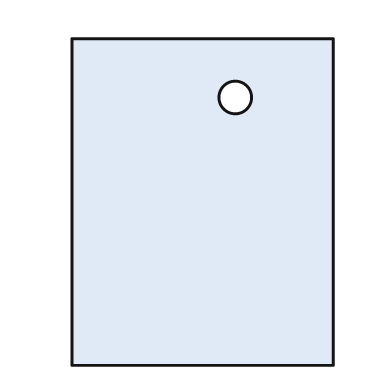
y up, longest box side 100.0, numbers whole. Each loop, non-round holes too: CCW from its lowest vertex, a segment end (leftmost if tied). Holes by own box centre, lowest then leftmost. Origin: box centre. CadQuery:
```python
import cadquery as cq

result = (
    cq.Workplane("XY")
    .moveTo(-40.0, -50.0)
    .lineTo(40.0, -50.0)
    .lineTo(40.0, 50.0)
    .lineTo(-40.0, 50.0)
    .close()
    .moveTo(10.0, 32.0)
    .circle(5.0)
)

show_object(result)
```